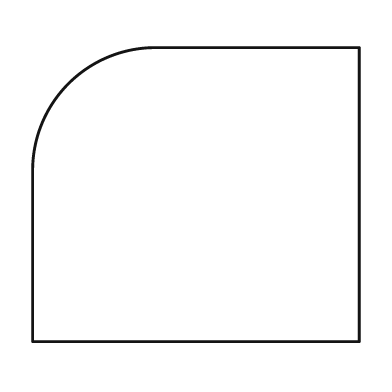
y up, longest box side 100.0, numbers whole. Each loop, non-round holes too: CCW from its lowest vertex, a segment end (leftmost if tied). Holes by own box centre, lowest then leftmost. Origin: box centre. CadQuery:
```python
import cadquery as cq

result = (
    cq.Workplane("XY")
    .moveTo(-50.0, -45.0)
    .lineTo(50.0, -45.0)
    .lineTo(50.0, 45.0)
    .lineTo(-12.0, 45.0)
    .threePointArc((-39.0, 34.0), (-50.0, 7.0))
    .close()
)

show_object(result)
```